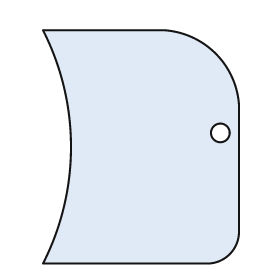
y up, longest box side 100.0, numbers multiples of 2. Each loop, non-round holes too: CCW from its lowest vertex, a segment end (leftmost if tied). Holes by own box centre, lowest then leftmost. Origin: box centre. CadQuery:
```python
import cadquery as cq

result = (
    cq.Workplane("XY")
    .moveTo(-42.0, -50.0)
    .lineTo(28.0, -50.0)
    .threePointArc((38.0, -46.0), (42.0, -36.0))
    .lineTo(42.0, 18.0)
    .threePointArc((32.0, 40.0), (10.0, 50.0))
    .lineTo(-42.0, 50.0)
    .threePointArc((-30.0, 0.0), (-42.0, -50.0))
    .close()
    .moveTo(34.0, 6.0)
    .circle(4.0)
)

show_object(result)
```